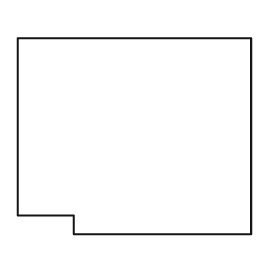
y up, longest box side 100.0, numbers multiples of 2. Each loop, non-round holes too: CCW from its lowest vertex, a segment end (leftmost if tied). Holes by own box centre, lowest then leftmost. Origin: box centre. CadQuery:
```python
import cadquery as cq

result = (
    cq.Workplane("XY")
    .moveTo(-26.0, -42.0)
    .lineTo(50.0, -42.0)
    .lineTo(50.0, 42.0)
    .lineTo(-50.0, 42.0)
    .lineTo(-50.0, -34.0)
    .lineTo(-26.0, -34.0)
    .close()
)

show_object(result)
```